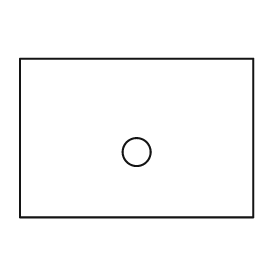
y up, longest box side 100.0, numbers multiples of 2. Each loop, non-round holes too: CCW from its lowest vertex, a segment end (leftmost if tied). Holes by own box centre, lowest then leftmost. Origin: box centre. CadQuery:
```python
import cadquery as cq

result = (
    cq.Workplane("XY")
    .moveTo(-50.0, -34.0)
    .lineTo(50.0, -34.0)
    .lineTo(50.0, 34.0)
    .lineTo(-50.0, 34.0)
    .close()
    .moveTo(0.0, -6.0)
    .circle(6.0)
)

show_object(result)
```